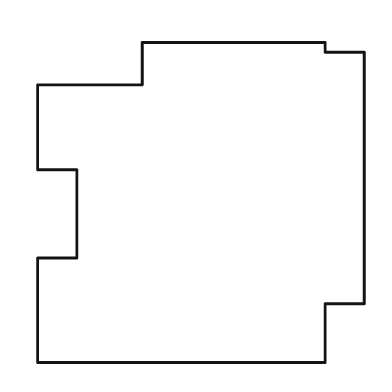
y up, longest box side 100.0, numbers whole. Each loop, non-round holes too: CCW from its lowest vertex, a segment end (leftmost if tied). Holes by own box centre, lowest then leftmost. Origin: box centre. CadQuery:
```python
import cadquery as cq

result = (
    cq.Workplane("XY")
    .moveTo(-50.0, -49.0)
    .lineTo(38.0, -49.0)
    .lineTo(38.0, -31.0)
    .lineTo(50.0, -31.0)
    .lineTo(50.0, 46.0)
    .lineTo(38.0, 46.0)
    .lineTo(38.0, 49.0)
    .lineTo(-18.0, 49.0)
    .lineTo(-18.0, 36.0)
    .lineTo(-50.0, 36.0)
    .lineTo(-50.0, 10.0)
    .lineTo(-38.0, 10.0)
    .lineTo(-38.0, -17.0)
    .lineTo(-50.0, -17.0)
    .close()
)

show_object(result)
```